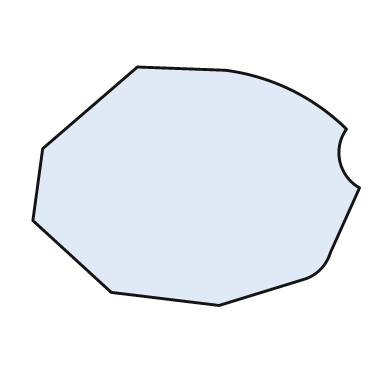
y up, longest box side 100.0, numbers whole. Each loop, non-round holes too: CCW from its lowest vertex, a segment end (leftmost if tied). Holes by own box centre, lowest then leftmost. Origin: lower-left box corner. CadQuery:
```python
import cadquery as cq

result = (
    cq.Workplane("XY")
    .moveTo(57.0, 0.0)
    .lineTo(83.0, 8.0)
    .threePointArc((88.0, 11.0), (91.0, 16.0))
    .lineTo(100.0, 36.0)
    .threePointArc((94.0, 44.0), (96.0, 54.0))
    .threePointArc((79.0, 66.0), (59.0, 72.0))
    .lineTo(32.0, 73.0)
    .lineTo(3.0, 48.0)
    .lineTo(0.0, 26.0)
    .lineTo(24.0, 4.0)
    .close()
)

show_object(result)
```